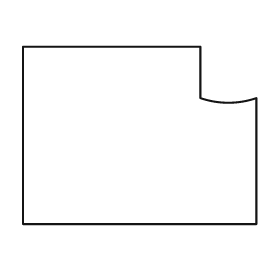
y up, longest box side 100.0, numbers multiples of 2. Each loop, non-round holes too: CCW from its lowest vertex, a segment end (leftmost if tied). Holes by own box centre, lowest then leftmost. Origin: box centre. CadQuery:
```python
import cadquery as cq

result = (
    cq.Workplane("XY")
    .moveTo(-50.0, -38.0)
    .lineTo(50.0, -38.0)
    .lineTo(50.0, 16.0)
    .threePointArc((38.0, 14.0), (26.0, 16.0))
    .lineTo(26.0, 38.0)
    .lineTo(-50.0, 38.0)
    .close()
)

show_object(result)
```